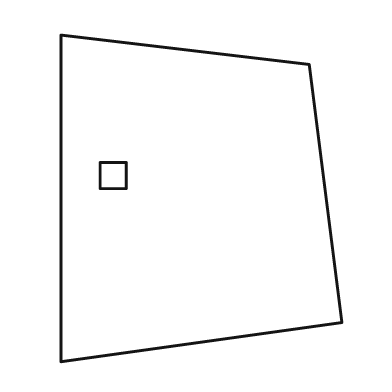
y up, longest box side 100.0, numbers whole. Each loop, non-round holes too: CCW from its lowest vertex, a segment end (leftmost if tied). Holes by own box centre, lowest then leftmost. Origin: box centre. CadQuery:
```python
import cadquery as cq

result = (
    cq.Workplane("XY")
    .moveTo(-43.0, -50.0)
    .lineTo(43.0, -38.0)
    .lineTo(33.0, 41.0)
    .lineTo(-43.0, 50.0)
    .close()
    .moveTo(-31.0, 3.0)
    .lineTo(-23.0, 3.0)
    .lineTo(-23.0, 11.0)
    .lineTo(-31.0, 11.0)
    .close()
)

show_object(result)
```